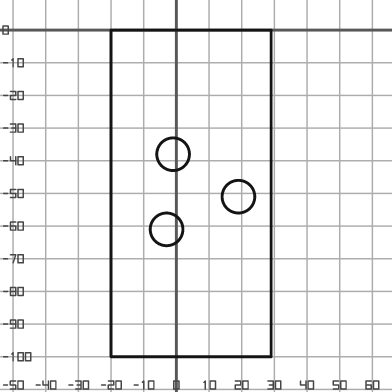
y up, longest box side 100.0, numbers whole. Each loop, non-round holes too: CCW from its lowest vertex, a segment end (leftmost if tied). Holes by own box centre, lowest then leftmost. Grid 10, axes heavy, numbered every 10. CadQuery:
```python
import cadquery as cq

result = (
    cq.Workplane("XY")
    .moveTo(-20.0, -100.0)
    .lineTo(29.0, -100.0)
    .lineTo(29.0, 0.0)
    .lineTo(-20.0, 0.0)
    .close()
    .moveTo(-3.0, -61.0)
    .circle(5.0)
    .moveTo(19.0, -51.0)
    .circle(5.0)
    .moveTo(-1.0, -38.0)
    .circle(5.0)
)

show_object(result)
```